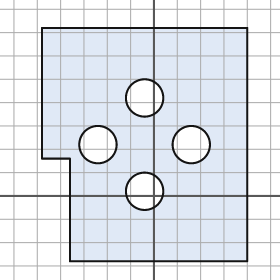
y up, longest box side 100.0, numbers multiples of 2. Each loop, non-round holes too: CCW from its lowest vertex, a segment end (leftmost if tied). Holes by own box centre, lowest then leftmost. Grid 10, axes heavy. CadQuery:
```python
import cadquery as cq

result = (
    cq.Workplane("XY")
    .moveTo(-36.0, -28.0)
    .lineTo(40.0, -28.0)
    .lineTo(40.0, 72.0)
    .lineTo(-48.0, 72.0)
    .lineTo(-48.0, 16.0)
    .lineTo(-36.0, 16.0)
    .close()
    .moveTo(-4.0, 2.0)
    .circle(8.0)
    .moveTo(-24.0, 22.0)
    .circle(8.0)
    .moveTo(16.0, 22.0)
    .circle(8.0)
    .moveTo(-4.0, 42.0)
    .circle(8.0)
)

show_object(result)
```